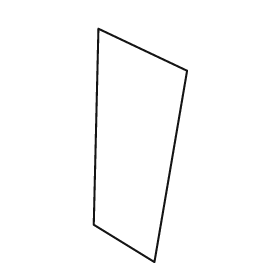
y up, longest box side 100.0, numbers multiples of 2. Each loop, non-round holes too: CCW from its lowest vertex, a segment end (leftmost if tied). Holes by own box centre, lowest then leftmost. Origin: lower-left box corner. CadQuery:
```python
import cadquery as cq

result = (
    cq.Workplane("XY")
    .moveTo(26.0, 0.0)
    .lineTo(40.0, 82.0)
    .lineTo(2.0, 100.0)
    .lineTo(0.0, 16.0)
    .close()
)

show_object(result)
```